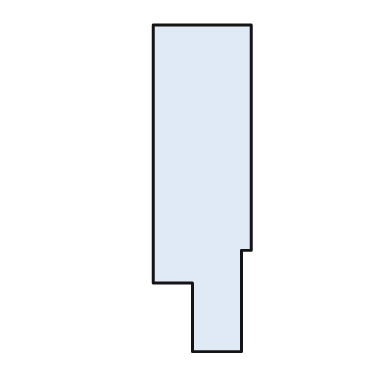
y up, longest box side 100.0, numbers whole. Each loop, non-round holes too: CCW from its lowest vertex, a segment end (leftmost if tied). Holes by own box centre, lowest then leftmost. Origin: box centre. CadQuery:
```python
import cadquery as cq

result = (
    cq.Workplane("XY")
    .moveTo(-3.0, -50.0)
    .lineTo(12.0, -50.0)
    .lineTo(12.0, -19.0)
    .lineTo(15.0, -19.0)
    .lineTo(15.0, 50.0)
    .lineTo(-15.0, 50.0)
    .lineTo(-15.0, -29.0)
    .lineTo(-3.0, -29.0)
    .close()
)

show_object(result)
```